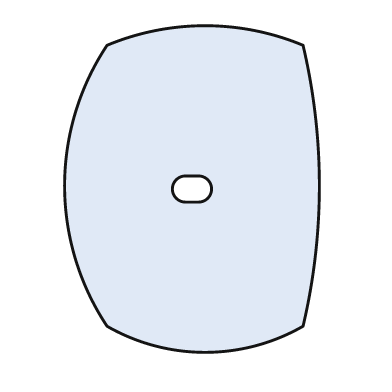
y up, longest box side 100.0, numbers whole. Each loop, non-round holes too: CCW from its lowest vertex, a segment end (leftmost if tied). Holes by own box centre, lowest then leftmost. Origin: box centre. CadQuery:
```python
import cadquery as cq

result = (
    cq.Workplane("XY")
    .moveTo(-26.0, -42.0)
    .threePointArc((4.0, -50.0), (34.0, -42.0))
    .threePointArc((39.0, 1.0), (34.0, 44.0))
    .threePointArc((4.0, 50.0), (-26.0, 44.0))
    .threePointArc((-39.0, 1.0), (-26.0, -42.0))
    .close()
    .moveTo(-2.0, -4.0)
    .lineTo(2.0, -4.0)
    .threePointArc((6.0, 0.0), (2.0, 4.0))
    .lineTo(-2.0, 4.0)
    .threePointArc((-6.0, 0.0), (-2.0, -4.0))
    .close()
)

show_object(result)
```